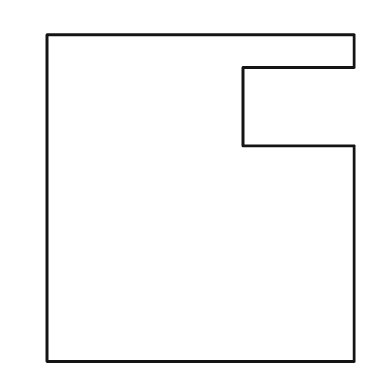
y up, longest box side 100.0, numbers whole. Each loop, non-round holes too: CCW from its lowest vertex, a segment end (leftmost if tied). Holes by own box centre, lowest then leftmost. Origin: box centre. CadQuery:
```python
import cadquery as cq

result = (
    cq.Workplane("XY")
    .moveTo(-47.0, -50.0)
    .lineTo(47.0, -50.0)
    .lineTo(47.0, 16.0)
    .lineTo(13.0, 16.0)
    .lineTo(13.0, 40.0)
    .lineTo(47.0, 40.0)
    .lineTo(47.0, 50.0)
    .lineTo(-47.0, 50.0)
    .close()
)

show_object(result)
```